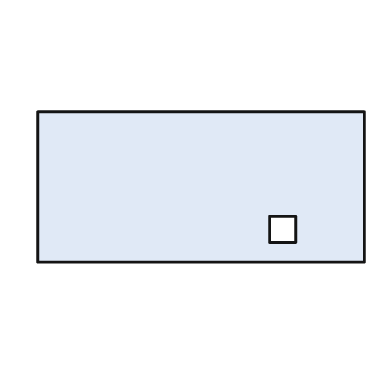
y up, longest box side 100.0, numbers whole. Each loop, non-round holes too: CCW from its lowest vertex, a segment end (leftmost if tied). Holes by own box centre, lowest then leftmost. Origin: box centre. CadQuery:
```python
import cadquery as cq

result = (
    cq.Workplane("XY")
    .moveTo(-50.0, -23.0)
    .lineTo(50.0, -23.0)
    .lineTo(50.0, 23.0)
    .lineTo(-50.0, 23.0)
    .close()
    .moveTo(21.0, -17.0)
    .lineTo(29.0, -17.0)
    .lineTo(29.0, -9.0)
    .lineTo(21.0, -9.0)
    .close()
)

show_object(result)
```